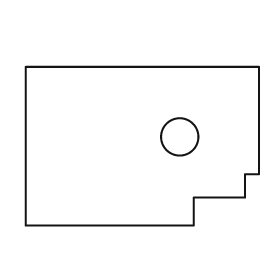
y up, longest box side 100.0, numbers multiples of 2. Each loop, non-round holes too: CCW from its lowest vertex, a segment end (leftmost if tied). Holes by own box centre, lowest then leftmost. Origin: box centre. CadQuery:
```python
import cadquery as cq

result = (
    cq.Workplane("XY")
    .moveTo(-50.0, -34.0)
    .lineTo(22.0, -34.0)
    .lineTo(22.0, -22.0)
    .lineTo(44.0, -22.0)
    .lineTo(44.0, -12.0)
    .lineTo(50.0, -12.0)
    .lineTo(50.0, 34.0)
    .lineTo(-50.0, 34.0)
    .close()
    .moveTo(16.0, 4.0)
    .circle(8.0)
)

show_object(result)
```